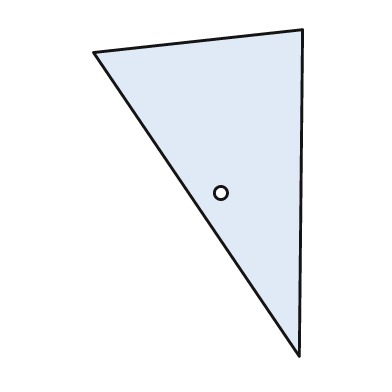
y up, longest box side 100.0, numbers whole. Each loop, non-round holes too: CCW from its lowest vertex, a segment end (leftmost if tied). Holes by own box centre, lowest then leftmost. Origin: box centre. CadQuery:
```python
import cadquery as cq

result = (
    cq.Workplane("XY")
    .moveTo(31.0, -50.0)
    .lineTo(32.0, 50.0)
    .lineTo(-32.0, 43.0)
    .close()
    .moveTo(7.0, 0.0)
    .circle(2.0)
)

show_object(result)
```